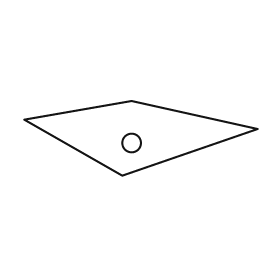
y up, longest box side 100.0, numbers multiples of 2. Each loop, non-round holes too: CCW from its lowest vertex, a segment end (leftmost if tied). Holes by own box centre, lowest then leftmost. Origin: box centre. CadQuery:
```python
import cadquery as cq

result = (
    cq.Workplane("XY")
    .moveTo(-8.0, -16.0)
    .lineTo(50.0, 4.0)
    .lineTo(-4.0, 16.0)
    .lineTo(-50.0, 8.0)
    .close()
    .moveTo(-4.0, -2.0)
    .circle(4.0)
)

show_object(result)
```